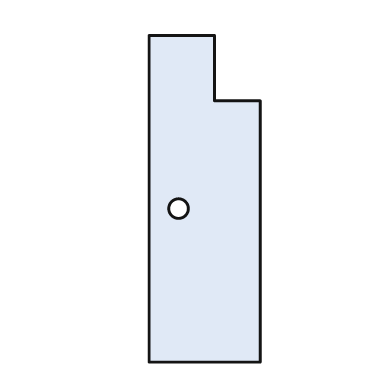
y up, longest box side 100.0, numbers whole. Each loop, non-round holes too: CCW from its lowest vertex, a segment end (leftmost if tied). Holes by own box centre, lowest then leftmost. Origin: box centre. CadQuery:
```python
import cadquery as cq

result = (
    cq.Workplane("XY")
    .moveTo(-17.0, -50.0)
    .lineTo(17.0, -50.0)
    .lineTo(17.0, 30.0)
    .lineTo(3.0, 30.0)
    .lineTo(3.0, 50.0)
    .lineTo(-17.0, 50.0)
    .close()
    .moveTo(-8.0, -3.0)
    .circle(3.0)
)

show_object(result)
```